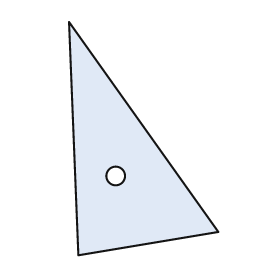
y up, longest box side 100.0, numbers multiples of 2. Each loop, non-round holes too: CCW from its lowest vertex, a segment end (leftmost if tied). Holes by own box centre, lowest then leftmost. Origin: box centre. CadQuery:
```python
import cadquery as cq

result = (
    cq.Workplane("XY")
    .moveTo(-28.0, -50.0)
    .lineTo(32.0, -40.0)
    .lineTo(-32.0, 50.0)
    .close()
    .moveTo(-12.0, -16.0)
    .circle(4.0)
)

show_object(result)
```